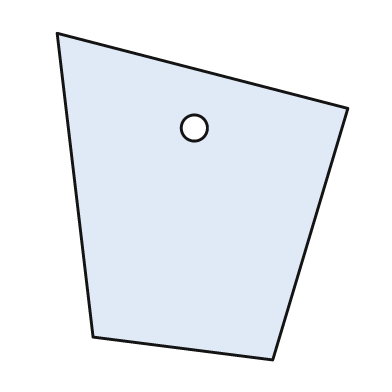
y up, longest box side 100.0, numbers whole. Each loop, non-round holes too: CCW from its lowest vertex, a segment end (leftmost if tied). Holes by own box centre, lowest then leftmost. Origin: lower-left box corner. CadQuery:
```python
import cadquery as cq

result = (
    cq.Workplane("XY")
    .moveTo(66.0, 0.0)
    .lineTo(89.0, 77.0)
    .lineTo(0.0, 100.0)
    .lineTo(11.0, 7.0)
    .close()
    .moveTo(42.0, 71.0)
    .circle(4.0)
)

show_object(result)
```